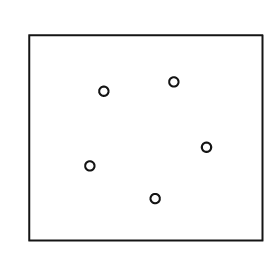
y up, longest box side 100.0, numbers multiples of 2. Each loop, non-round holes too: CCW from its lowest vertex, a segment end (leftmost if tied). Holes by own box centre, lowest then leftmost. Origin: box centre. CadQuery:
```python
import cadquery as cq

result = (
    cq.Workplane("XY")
    .moveTo(-50.0, -44.0)
    .lineTo(50.0, -44.0)
    .lineTo(50.0, 44.0)
    .lineTo(-50.0, 44.0)
    .close()
    .moveTo(4.0, -26.0)
    .circle(2.0)
    .moveTo(-24.0, -12.0)
    .circle(2.0)
    .moveTo(26.0, -4.0)
    .circle(2.0)
    .moveTo(-18.0, 20.0)
    .circle(2.0)
    .moveTo(12.0, 24.0)
    .circle(2.0)
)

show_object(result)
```